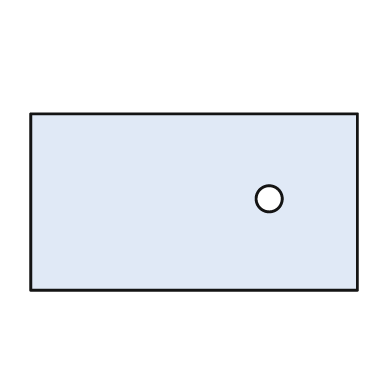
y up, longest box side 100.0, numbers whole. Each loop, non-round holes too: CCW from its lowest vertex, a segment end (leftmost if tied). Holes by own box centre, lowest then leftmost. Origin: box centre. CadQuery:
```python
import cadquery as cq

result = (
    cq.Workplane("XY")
    .moveTo(-50.0, -27.0)
    .lineTo(50.0, -27.0)
    .lineTo(50.0, 27.0)
    .lineTo(-50.0, 27.0)
    .close()
    .moveTo(23.0, 1.0)
    .circle(4.0)
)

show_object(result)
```